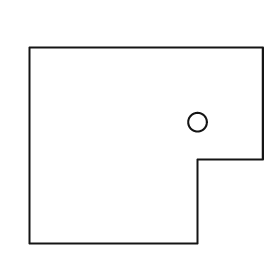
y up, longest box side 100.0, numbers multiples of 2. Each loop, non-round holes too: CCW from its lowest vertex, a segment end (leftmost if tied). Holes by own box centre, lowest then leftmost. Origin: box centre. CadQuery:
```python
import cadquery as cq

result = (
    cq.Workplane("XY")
    .moveTo(-50.0, -42.0)
    .lineTo(22.0, -42.0)
    .lineTo(22.0, -6.0)
    .lineTo(50.0, -6.0)
    .lineTo(50.0, 42.0)
    .lineTo(-50.0, 42.0)
    .close()
    .moveTo(22.0, 10.0)
    .circle(4.0)
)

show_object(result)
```